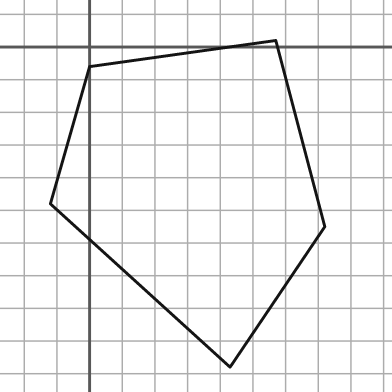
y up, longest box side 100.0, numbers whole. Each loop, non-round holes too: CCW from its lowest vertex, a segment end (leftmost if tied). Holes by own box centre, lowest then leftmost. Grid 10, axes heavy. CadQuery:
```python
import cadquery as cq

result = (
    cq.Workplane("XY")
    .moveTo(43.0, -98.0)
    .lineTo(72.0, -55.0)
    .lineTo(57.0, 2.0)
    .lineTo(0.0, -6.0)
    .lineTo(-12.0, -48.0)
    .close()
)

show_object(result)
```